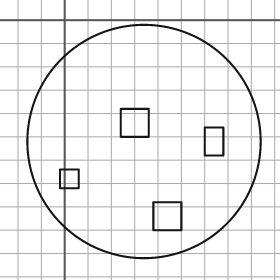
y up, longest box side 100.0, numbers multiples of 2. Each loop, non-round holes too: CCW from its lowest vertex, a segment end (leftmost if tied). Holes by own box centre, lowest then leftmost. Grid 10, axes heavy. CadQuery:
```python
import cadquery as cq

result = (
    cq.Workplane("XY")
    .moveTo(34.0, -52.0)
    .circle(50.0)
    .moveTo(38.0, -90.0)
    .lineTo(50.0, -90.0)
    .lineTo(50.0, -78.0)
    .lineTo(38.0, -78.0)
    .close()
    .moveTo(-2.0, -72.0)
    .lineTo(6.0, -72.0)
    .lineTo(6.0, -64.0)
    .lineTo(-2.0, -64.0)
    .close()
    .moveTo(60.0, -58.0)
    .lineTo(68.0, -58.0)
    .lineTo(68.0, -46.0)
    .lineTo(60.0, -46.0)
    .close()
    .moveTo(24.0, -50.0)
    .lineTo(36.0, -50.0)
    .lineTo(36.0, -38.0)
    .lineTo(24.0, -38.0)
    .close()
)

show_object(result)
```